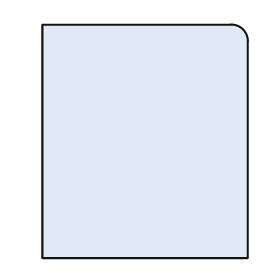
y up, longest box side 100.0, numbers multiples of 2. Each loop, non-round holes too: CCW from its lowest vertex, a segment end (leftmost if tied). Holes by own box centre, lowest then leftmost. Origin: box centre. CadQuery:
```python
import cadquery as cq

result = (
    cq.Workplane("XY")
    .moveTo(-44.0, -50.0)
    .lineTo(44.0, -50.0)
    .lineTo(44.0, 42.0)
    .threePointArc((42.0, 48.0), (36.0, 50.0))
    .lineTo(-44.0, 50.0)
    .close()
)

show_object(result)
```